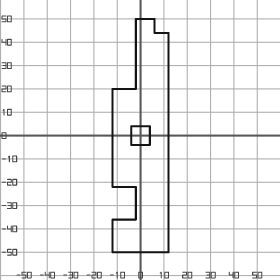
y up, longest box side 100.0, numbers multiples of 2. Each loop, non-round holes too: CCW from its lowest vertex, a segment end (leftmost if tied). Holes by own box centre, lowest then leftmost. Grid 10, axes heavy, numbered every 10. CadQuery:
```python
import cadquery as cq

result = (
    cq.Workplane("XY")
    .moveTo(-12.0, -50.0)
    .lineTo(12.0, -50.0)
    .lineTo(12.0, 44.0)
    .lineTo(6.0, 44.0)
    .lineTo(6.0, 50.0)
    .lineTo(-2.0, 50.0)
    .lineTo(-2.0, 20.0)
    .lineTo(-12.0, 20.0)
    .lineTo(-12.0, -22.0)
    .lineTo(-2.0, -22.0)
    .lineTo(-2.0, -36.0)
    .lineTo(-12.0, -36.0)
    .close()
    .moveTo(-4.0, -4.0)
    .lineTo(4.0, -4.0)
    .lineTo(4.0, 4.0)
    .lineTo(-4.0, 4.0)
    .close()
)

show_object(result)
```